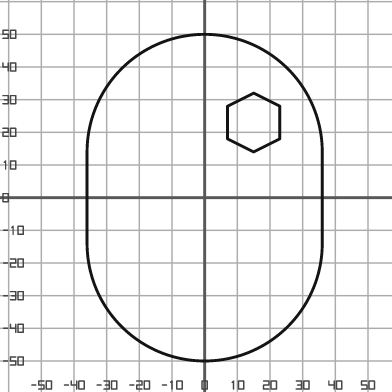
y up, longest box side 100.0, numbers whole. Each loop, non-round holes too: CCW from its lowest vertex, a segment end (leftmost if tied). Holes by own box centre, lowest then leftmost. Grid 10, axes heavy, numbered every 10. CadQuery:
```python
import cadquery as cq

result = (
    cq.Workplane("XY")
    .moveTo(-36.0, -14.0)
    .threePointArc((0.0, -50.0), (36.0, -14.0))
    .lineTo(36.0, 14.0)
    .threePointArc((0.0, 50.0), (-36.0, 14.0))
    .close()
    .moveTo(15.0, 14.0)
    .lineTo(23.0, 18.0)
    .lineTo(23.0, 28.0)
    .lineTo(15.0, 32.0)
    .lineTo(7.0, 28.0)
    .lineTo(7.0, 18.0)
    .close()
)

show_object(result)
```